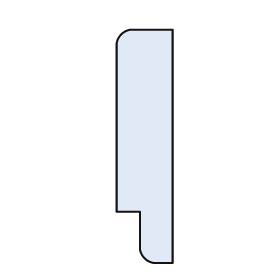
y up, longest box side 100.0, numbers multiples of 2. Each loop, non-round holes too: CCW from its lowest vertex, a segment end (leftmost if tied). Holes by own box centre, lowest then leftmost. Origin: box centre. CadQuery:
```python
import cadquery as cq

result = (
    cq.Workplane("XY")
    .moveTo(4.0, -50.0)
    .lineTo(12.0, -50.0)
    .lineTo(12.0, 50.0)
    .lineTo(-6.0, 50.0)
    .threePointArc((-10.0, 48.0), (-12.0, 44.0))
    .lineTo(-12.0, -28.0)
    .lineTo(-2.0, -28.0)
    .lineTo(-2.0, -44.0)
    .threePointArc((0.0, -48.0), (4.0, -50.0))
    .close()
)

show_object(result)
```